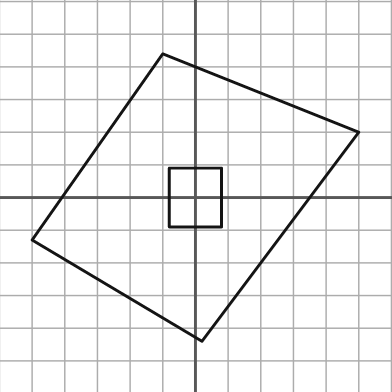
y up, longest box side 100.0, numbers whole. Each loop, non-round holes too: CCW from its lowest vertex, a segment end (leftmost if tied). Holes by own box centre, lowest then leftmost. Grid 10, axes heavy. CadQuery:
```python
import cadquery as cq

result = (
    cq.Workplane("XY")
    .moveTo(2.0, -44.0)
    .lineTo(50.0, 20.0)
    .lineTo(-10.0, 44.0)
    .lineTo(-50.0, -13.0)
    .close()
    .moveTo(-8.0, -9.0)
    .lineTo(8.0, -9.0)
    .lineTo(8.0, 9.0)
    .lineTo(-8.0, 9.0)
    .close()
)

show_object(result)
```